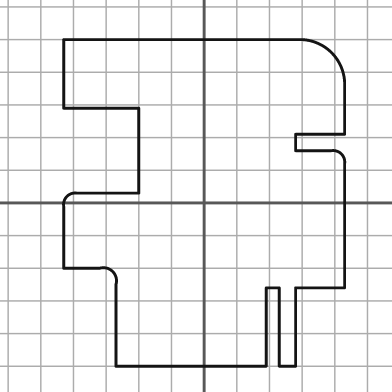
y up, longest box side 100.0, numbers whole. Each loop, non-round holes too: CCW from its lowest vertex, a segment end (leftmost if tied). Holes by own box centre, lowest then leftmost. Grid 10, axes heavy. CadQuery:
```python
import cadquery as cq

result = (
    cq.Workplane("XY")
    .moveTo(-27.0, -50.0)
    .lineTo(19.0, -50.0)
    .lineTo(19.0, -26.0)
    .lineTo(23.0, -26.0)
    .lineTo(23.0, -50.0)
    .lineTo(28.0, -50.0)
    .lineTo(28.0, -26.0)
    .lineTo(43.0, -26.0)
    .lineTo(43.0, 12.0)
    .threePointArc((42.0, 15.0), (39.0, 16.0))
    .lineTo(28.0, 16.0)
    .lineTo(28.0, 21.0)
    .lineTo(43.0, 21.0)
    .lineTo(43.0, 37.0)
    .threePointArc((39.0, 46.0), (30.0, 50.0))
    .lineTo(-43.0, 50.0)
    .lineTo(-43.0, 29.0)
    .lineTo(-20.0, 29.0)
    .lineTo(-20.0, 3.0)
    .lineTo(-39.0, 3.0)
    .threePointArc((-42.0, 2.0), (-43.0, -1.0))
    .lineTo(-43.0, -20.0)
    .lineTo(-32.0, -20.0)
    .threePointArc((-28.0, -21.0), (-27.0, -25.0))
    .close()
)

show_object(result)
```